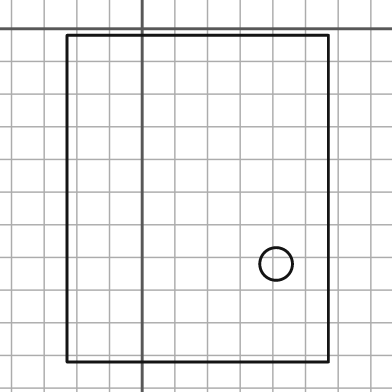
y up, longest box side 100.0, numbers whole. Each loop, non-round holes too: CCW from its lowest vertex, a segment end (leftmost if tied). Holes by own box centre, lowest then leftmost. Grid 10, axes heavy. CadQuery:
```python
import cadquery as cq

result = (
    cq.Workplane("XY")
    .moveTo(-23.0, -102.0)
    .lineTo(57.0, -102.0)
    .lineTo(57.0, -2.0)
    .lineTo(-23.0, -2.0)
    .close()
    .moveTo(41.0, -72.0)
    .circle(5.0)
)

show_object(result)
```